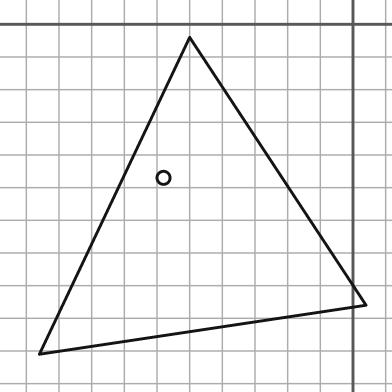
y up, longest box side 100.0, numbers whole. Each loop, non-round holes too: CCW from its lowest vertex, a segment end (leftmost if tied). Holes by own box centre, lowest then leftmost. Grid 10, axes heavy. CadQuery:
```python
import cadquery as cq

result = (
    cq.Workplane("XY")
    .moveTo(-96.0, -101.0)
    .lineTo(4.0, -86.0)
    .lineTo(-50.0, -4.0)
    .close()
    .moveTo(-58.0, -47.0)
    .circle(2.0)
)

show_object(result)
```